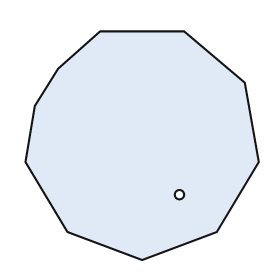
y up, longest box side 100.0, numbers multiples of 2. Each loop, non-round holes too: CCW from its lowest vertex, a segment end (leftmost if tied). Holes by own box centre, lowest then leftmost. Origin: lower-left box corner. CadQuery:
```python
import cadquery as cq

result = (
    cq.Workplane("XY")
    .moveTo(50.0, 0.0)
    .lineTo(82.0, 12.0)
    .lineTo(100.0, 42.0)
    .lineTo(94.0, 76.0)
    .lineTo(68.0, 98.0)
    .lineTo(32.0, 98.0)
    .lineTo(14.0, 82.0)
    .lineTo(4.0, 66.0)
    .lineTo(0.0, 42.0)
    .lineTo(18.0, 12.0)
    .close()
    .moveTo(66.0, 28.0)
    .circle(2.0)
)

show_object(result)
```